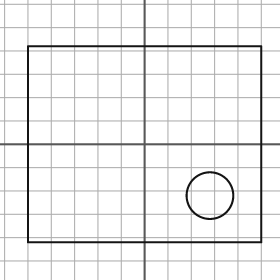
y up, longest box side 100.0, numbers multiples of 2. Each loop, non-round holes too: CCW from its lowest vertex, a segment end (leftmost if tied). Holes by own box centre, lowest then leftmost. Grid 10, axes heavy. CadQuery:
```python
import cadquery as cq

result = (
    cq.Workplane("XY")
    .moveTo(-50.0, -42.0)
    .lineTo(50.0, -42.0)
    .lineTo(50.0, 42.0)
    .lineTo(-50.0, 42.0)
    .close()
    .moveTo(28.0, -22.0)
    .circle(10.0)
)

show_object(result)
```